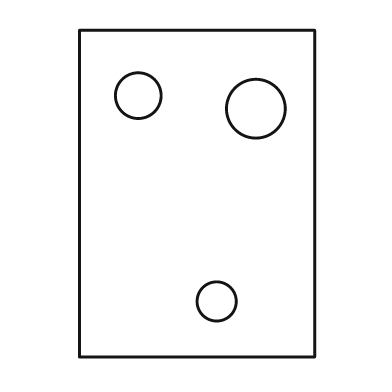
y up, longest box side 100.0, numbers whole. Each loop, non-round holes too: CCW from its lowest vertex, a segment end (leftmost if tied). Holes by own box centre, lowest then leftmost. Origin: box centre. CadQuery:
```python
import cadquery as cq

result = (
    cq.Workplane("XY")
    .moveTo(-36.0, -50.0)
    .lineTo(36.0, -50.0)
    .lineTo(36.0, 50.0)
    .lineTo(-36.0, 50.0)
    .close()
    .moveTo(6.0, -33.0)
    .circle(6.0)
    .moveTo(18.0, 26.0)
    .circle(9.0)
    .moveTo(-18.0, 30.0)
    .circle(7.0)
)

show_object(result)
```